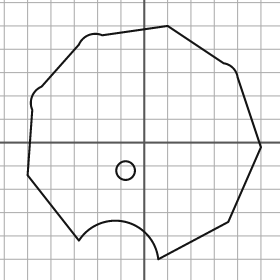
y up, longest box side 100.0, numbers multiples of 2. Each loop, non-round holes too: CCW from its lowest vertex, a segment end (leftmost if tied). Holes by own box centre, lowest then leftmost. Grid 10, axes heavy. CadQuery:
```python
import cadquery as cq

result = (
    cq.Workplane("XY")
    .moveTo(6.0, -50.0)
    .lineTo(36.0, -34.0)
    .lineTo(50.0, -2.0)
    .lineTo(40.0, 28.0)
    .threePointArc((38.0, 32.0), (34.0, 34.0))
    .lineTo(10.0, 50.0)
    .lineTo(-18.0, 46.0)
    .threePointArc((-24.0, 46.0), (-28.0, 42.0))
    .lineTo(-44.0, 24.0)
    .threePointArc((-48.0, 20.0), (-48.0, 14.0))
    .lineTo(-50.0, -14.0)
    .lineTo(-28.0, -42.0)
    .threePointArc((-8.0, -34.0), (6.0, -50.0))
    .close()
    .moveTo(-8.0, -12.0)
    .circle(4.0)
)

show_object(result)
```